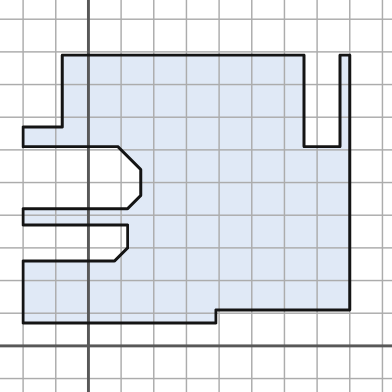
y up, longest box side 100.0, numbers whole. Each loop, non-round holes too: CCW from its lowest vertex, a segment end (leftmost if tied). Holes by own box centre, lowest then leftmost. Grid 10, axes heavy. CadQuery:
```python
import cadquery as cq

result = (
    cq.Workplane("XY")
    .moveTo(-20.0, 7.0)
    .lineTo(39.0, 7.0)
    .lineTo(39.0, 11.0)
    .lineTo(80.0, 11.0)
    .lineTo(80.0, 89.0)
    .lineTo(77.0, 89.0)
    .lineTo(77.0, 61.0)
    .lineTo(66.0, 61.0)
    .lineTo(66.0, 89.0)
    .lineTo(-8.0, 89.0)
    .lineTo(-8.0, 67.0)
    .lineTo(-20.0, 67.0)
    .lineTo(-20.0, 61.0)
    .lineTo(9.0, 61.0)
    .lineTo(16.0, 54.0)
    .lineTo(16.0, 46.0)
    .lineTo(12.0, 42.0)
    .lineTo(-20.0, 42.0)
    .lineTo(-20.0, 37.0)
    .lineTo(12.0, 37.0)
    .lineTo(12.0, 30.0)
    .lineTo(8.0, 26.0)
    .lineTo(-20.0, 26.0)
    .close()
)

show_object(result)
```